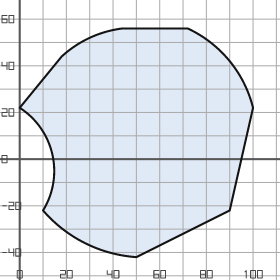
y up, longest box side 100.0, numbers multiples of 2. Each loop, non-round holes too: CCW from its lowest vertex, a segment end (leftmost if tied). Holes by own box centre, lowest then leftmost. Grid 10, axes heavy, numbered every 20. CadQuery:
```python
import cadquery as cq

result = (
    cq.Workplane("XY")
    .moveTo(50.0, -42.0)
    .lineTo(90.0, -22.0)
    .lineTo(100.0, 22.0)
    .threePointArc((90.0, 42.0), (72.0, 56.0))
    .lineTo(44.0, 56.0)
    .threePointArc((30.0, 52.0), (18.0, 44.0))
    .lineTo(0.0, 22.0)
    .threePointArc((14.0, 2.0), (10.0, -22.0))
    .threePointArc((28.0, -36.0), (50.0, -42.0))
    .close()
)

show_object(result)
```